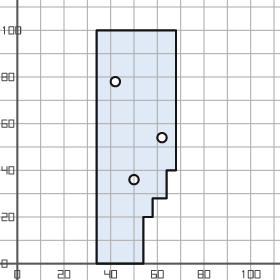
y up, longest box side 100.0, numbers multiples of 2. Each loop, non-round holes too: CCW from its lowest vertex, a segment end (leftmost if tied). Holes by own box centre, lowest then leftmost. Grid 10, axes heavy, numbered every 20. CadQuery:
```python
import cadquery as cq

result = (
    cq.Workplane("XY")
    .moveTo(34.0, 0.0)
    .lineTo(54.0, 0.0)
    .lineTo(54.0, 20.0)
    .lineTo(58.0, 20.0)
    .lineTo(58.0, 28.0)
    .lineTo(64.0, 28.0)
    .lineTo(64.0, 40.0)
    .lineTo(68.0, 40.0)
    .lineTo(68.0, 100.0)
    .lineTo(34.0, 100.0)
    .close()
    .moveTo(50.0, 36.0)
    .circle(2.0)
    .moveTo(62.0, 54.0)
    .circle(2.0)
    .moveTo(42.0, 78.0)
    .circle(2.0)
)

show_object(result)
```